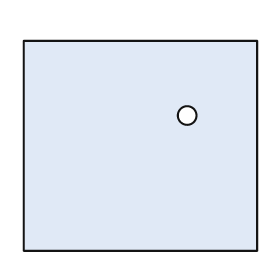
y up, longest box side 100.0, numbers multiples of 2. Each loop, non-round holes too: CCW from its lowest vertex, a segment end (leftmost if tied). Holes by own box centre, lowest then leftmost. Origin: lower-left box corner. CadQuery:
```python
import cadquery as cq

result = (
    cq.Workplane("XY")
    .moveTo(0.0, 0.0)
    .lineTo(100.0, 0.0)
    .lineTo(100.0, 90.0)
    .lineTo(0.0, 90.0)
    .close()
    .moveTo(70.0, 58.0)
    .circle(4.0)
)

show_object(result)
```